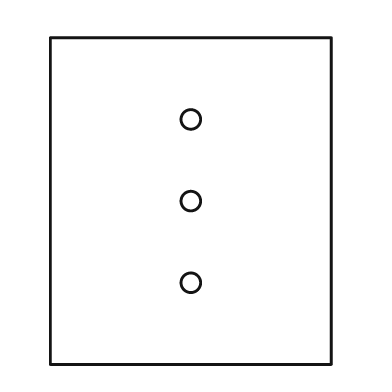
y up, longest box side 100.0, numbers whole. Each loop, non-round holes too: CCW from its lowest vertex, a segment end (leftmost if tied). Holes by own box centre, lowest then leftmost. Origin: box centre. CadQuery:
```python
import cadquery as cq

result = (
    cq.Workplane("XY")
    .moveTo(-43.0, -50.0)
    .lineTo(43.0, -50.0)
    .lineTo(43.0, 50.0)
    .lineTo(-43.0, 50.0)
    .close()
    .moveTo(0.0, -25.0)
    .circle(3.0)
    .moveTo(0.0, 0.0)
    .circle(3.0)
    .moveTo(0.0, 25.0)
    .circle(3.0)
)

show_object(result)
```